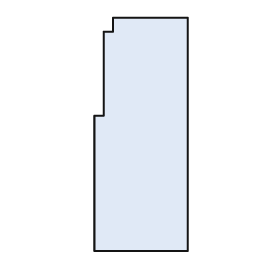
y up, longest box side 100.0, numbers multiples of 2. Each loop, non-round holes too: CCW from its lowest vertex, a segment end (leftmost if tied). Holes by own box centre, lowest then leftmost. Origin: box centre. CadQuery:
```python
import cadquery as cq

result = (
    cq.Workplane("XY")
    .moveTo(-20.0, -50.0)
    .lineTo(20.0, -50.0)
    .lineTo(20.0, 50.0)
    .lineTo(-12.0, 50.0)
    .lineTo(-12.0, 44.0)
    .lineTo(-16.0, 44.0)
    .lineTo(-16.0, 8.0)
    .lineTo(-20.0, 8.0)
    .close()
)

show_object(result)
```